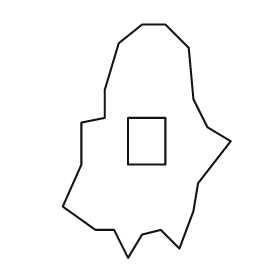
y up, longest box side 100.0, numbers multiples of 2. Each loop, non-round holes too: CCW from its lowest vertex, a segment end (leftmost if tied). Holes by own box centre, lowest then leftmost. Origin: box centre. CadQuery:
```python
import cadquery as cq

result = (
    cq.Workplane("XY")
    .moveTo(-8.0, -50.0)
    .lineTo(-2.0, -40.0)
    .lineTo(6.0, -38.0)
    .lineTo(14.0, -46.0)
    .lineTo(20.0, -30.0)
    .lineTo(22.0, -18.0)
    .lineTo(36.0, 0.0)
    .lineTo(26.0, 6.0)
    .lineTo(20.0, 18.0)
    .lineTo(18.0, 40.0)
    .lineTo(8.0, 50.0)
    .lineTo(-2.0, 50.0)
    .lineTo(-12.0, 42.0)
    .lineTo(-18.0, 22.0)
    .lineTo(-18.0, 10.0)
    .lineTo(-28.0, 8.0)
    .lineTo(-28.0, -10.0)
    .lineTo(-36.0, -28.0)
    .lineTo(-22.0, -38.0)
    .lineTo(-14.0, -38.0)
    .close()
    .moveTo(-8.0, -10.0)
    .lineTo(8.0, -10.0)
    .lineTo(8.0, 10.0)
    .lineTo(-8.0, 10.0)
    .close()
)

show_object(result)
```